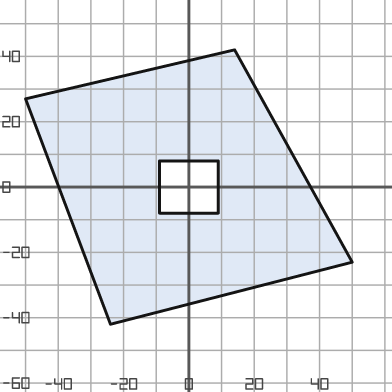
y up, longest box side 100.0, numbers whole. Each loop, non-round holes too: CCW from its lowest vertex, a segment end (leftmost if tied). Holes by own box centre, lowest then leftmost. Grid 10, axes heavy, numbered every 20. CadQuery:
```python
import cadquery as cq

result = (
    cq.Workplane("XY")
    .moveTo(-24.0, -42.0)
    .lineTo(50.0, -23.0)
    .lineTo(14.0, 42.0)
    .lineTo(-50.0, 27.0)
    .close()
    .moveTo(-9.0, -8.0)
    .lineTo(9.0, -8.0)
    .lineTo(9.0, 8.0)
    .lineTo(-9.0, 8.0)
    .close()
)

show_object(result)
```